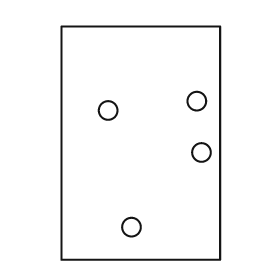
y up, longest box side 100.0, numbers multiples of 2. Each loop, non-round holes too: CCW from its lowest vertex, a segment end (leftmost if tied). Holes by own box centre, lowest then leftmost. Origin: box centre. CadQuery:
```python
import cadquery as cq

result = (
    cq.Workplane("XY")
    .moveTo(-34.0, -50.0)
    .lineTo(34.0, -50.0)
    .lineTo(34.0, 50.0)
    .lineTo(-34.0, 50.0)
    .close()
    .moveTo(-4.0, -36.0)
    .circle(4.0)
    .moveTo(26.0, -4.0)
    .circle(4.0)
    .moveTo(-14.0, 14.0)
    .circle(4.0)
    .moveTo(24.0, 18.0)
    .circle(4.0)
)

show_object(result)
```